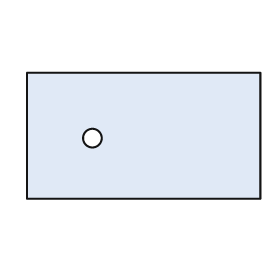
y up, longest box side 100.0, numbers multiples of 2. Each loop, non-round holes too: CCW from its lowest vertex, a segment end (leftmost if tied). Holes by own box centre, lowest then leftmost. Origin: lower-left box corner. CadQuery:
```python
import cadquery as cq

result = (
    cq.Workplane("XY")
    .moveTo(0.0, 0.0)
    .lineTo(100.0, 0.0)
    .lineTo(100.0, 54.0)
    .lineTo(0.0, 54.0)
    .close()
    .moveTo(28.0, 26.0)
    .circle(4.0)
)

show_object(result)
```